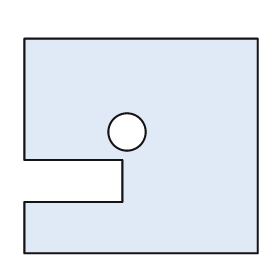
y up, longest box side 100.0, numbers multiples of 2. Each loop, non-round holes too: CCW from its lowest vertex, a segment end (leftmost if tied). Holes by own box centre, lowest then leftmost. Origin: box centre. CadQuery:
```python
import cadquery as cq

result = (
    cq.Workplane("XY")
    .moveTo(-50.0, -46.0)
    .lineTo(50.0, -46.0)
    .lineTo(50.0, 46.0)
    .lineTo(-50.0, 46.0)
    .lineTo(-50.0, -6.0)
    .lineTo(-8.0, -6.0)
    .lineTo(-8.0, -24.0)
    .lineTo(-50.0, -24.0)
    .close()
    .moveTo(-6.0, 6.0)
    .circle(8.0)
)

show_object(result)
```